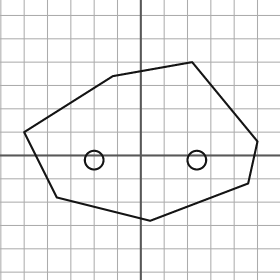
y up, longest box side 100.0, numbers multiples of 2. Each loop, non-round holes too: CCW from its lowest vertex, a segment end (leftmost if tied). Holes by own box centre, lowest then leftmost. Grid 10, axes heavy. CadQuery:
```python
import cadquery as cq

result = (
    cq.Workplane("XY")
    .moveTo(4.0, -28.0)
    .lineTo(46.0, -12.0)
    .lineTo(50.0, 6.0)
    .lineTo(22.0, 40.0)
    .lineTo(-12.0, 34.0)
    .lineTo(-50.0, 10.0)
    .lineTo(-36.0, -18.0)
    .close()
    .moveTo(-20.0, -2.0)
    .circle(4.0)
    .moveTo(24.0, -2.0)
    .circle(4.0)
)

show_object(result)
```